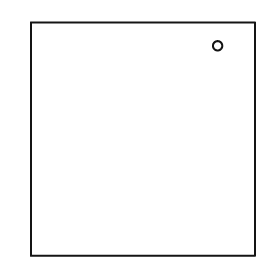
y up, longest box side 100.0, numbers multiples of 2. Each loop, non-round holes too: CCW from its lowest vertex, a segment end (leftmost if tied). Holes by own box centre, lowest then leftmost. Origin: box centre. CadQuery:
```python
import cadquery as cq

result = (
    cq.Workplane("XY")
    .moveTo(-48.0, -50.0)
    .lineTo(48.0, -50.0)
    .lineTo(48.0, 50.0)
    .lineTo(-48.0, 50.0)
    .close()
    .moveTo(32.0, 40.0)
    .circle(2.0)
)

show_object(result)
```